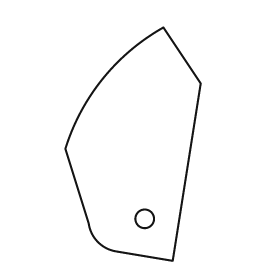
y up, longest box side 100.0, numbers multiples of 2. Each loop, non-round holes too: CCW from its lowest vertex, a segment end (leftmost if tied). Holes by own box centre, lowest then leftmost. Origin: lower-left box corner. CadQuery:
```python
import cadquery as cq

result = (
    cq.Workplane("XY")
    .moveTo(46.0, 0.0)
    .lineTo(58.0, 76.0)
    .lineTo(42.0, 100.0)
    .threePointArc((16.0, 78.0), (0.0, 48.0))
    .lineTo(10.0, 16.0)
    .threePointArc((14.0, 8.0), (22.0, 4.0))
    .close()
    .moveTo(34.0, 18.0)
    .circle(4.0)
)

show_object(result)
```